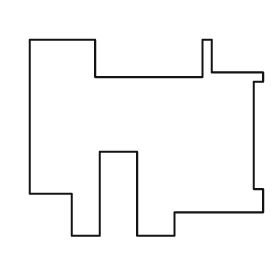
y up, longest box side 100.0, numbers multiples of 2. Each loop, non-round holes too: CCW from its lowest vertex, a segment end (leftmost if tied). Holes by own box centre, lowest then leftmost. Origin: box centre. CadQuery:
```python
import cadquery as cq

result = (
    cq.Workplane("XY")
    .moveTo(-32.0, -42.0)
    .lineTo(-20.0, -42.0)
    .lineTo(-20.0, -6.0)
    .lineTo(-4.0, -6.0)
    .lineTo(-4.0, -42.0)
    .lineTo(12.0, -42.0)
    .lineTo(12.0, -32.0)
    .lineTo(50.0, -32.0)
    .lineTo(50.0, -22.0)
    .lineTo(46.0, -22.0)
    .lineTo(46.0, 24.0)
    .lineTo(50.0, 24.0)
    .lineTo(50.0, 28.0)
    .lineTo(28.0, 28.0)
    .lineTo(28.0, 42.0)
    .lineTo(24.0, 42.0)
    .lineTo(24.0, 26.0)
    .lineTo(-22.0, 26.0)
    .lineTo(-22.0, 42.0)
    .lineTo(-50.0, 42.0)
    .lineTo(-50.0, -24.0)
    .lineTo(-32.0, -24.0)
    .close()
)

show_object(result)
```